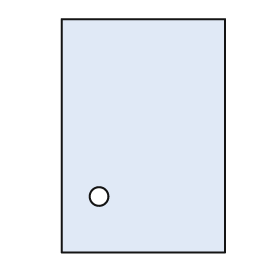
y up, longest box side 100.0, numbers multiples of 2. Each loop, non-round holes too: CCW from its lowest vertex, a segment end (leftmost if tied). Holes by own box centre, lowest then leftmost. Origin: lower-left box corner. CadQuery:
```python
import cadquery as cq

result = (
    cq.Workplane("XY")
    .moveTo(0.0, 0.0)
    .lineTo(70.0, 0.0)
    .lineTo(70.0, 100.0)
    .lineTo(0.0, 100.0)
    .close()
    .moveTo(16.0, 24.0)
    .circle(4.0)
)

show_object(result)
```